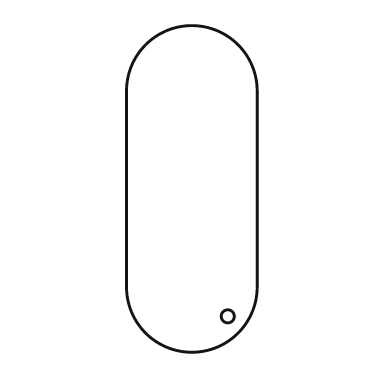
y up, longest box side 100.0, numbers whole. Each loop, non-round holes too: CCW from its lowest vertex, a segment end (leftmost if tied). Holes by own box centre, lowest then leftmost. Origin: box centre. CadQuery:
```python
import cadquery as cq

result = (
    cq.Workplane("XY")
    .moveTo(-20.0, -30.0)
    .threePointArc((0.0, -50.0), (20.0, -30.0))
    .lineTo(20.0, 30.0)
    .threePointArc((0.0, 50.0), (-20.0, 30.0))
    .close()
    .moveTo(11.0, -39.0)
    .circle(2.0)
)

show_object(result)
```